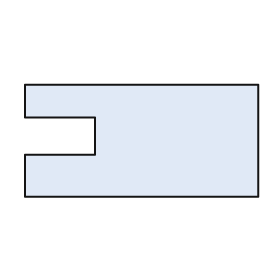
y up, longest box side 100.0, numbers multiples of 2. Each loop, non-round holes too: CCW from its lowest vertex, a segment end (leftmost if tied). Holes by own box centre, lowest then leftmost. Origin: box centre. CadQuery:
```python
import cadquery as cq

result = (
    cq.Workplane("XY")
    .moveTo(-50.0, -24.0)
    .lineTo(50.0, -24.0)
    .lineTo(50.0, 24.0)
    .lineTo(-50.0, 24.0)
    .lineTo(-50.0, 10.0)
    .lineTo(-20.0, 10.0)
    .lineTo(-20.0, -6.0)
    .lineTo(-50.0, -6.0)
    .close()
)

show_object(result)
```